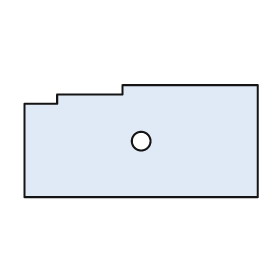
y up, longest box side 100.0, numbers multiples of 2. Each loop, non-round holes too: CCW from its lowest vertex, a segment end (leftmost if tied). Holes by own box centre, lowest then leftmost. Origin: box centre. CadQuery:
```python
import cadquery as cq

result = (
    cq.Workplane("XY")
    .moveTo(-50.0, -24.0)
    .lineTo(50.0, -24.0)
    .lineTo(50.0, 24.0)
    .lineTo(-8.0, 24.0)
    .lineTo(-8.0, 20.0)
    .lineTo(-36.0, 20.0)
    .lineTo(-36.0, 16.0)
    .lineTo(-50.0, 16.0)
    .close()
    .moveTo(0.0, 0.0)
    .circle(4.0)
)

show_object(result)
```